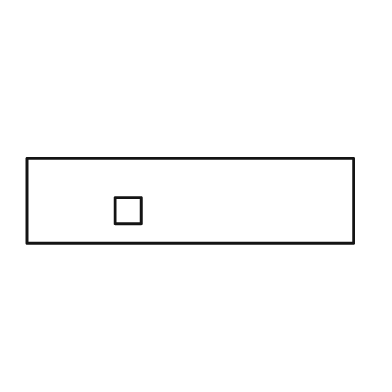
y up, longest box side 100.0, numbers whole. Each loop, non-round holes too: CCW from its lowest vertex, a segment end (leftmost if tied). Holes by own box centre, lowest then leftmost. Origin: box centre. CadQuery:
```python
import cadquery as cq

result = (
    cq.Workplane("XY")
    .moveTo(-50.0, -13.0)
    .lineTo(50.0, -13.0)
    .lineTo(50.0, 13.0)
    .lineTo(-50.0, 13.0)
    .close()
    .moveTo(-23.0, -7.0)
    .lineTo(-15.0, -7.0)
    .lineTo(-15.0, 1.0)
    .lineTo(-23.0, 1.0)
    .close()
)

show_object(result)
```